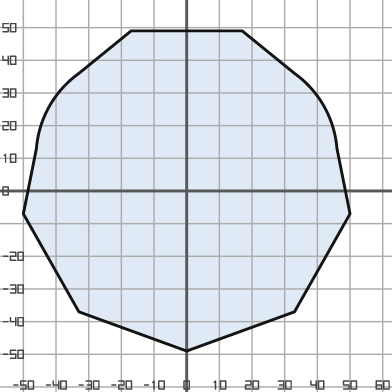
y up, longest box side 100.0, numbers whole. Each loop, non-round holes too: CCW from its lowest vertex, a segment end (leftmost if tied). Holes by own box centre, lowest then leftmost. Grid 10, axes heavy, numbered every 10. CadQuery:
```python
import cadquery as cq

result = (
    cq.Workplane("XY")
    .moveTo(0.0, -49.0)
    .lineTo(33.0, -37.0)
    .lineTo(50.0, -7.0)
    .lineTo(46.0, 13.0)
    .threePointArc((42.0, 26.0), (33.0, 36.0))
    .lineTo(17.0, 49.0)
    .lineTo(-17.0, 49.0)
    .lineTo(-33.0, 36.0)
    .threePointArc((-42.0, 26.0), (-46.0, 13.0))
    .lineTo(-50.0, -7.0)
    .lineTo(-33.0, -37.0)
    .close()
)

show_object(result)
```